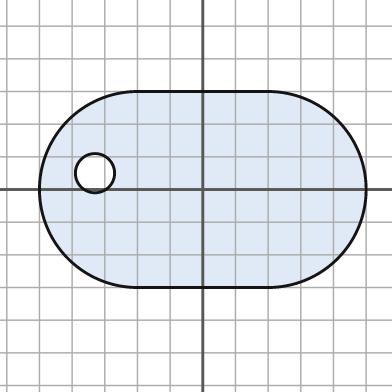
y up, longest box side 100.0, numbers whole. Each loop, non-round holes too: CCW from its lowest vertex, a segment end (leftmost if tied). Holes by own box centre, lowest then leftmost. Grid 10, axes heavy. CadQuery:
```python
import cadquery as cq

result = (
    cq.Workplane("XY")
    .moveTo(-20.0, -30.0)
    .lineTo(20.0, -30.0)
    .threePointArc((50.0, 0.0), (20.0, 30.0))
    .lineTo(-20.0, 30.0)
    .threePointArc((-50.0, 0.0), (-20.0, -30.0))
    .close()
    .moveTo(-33.0, 5.0)
    .circle(6.0)
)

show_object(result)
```